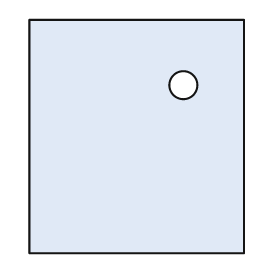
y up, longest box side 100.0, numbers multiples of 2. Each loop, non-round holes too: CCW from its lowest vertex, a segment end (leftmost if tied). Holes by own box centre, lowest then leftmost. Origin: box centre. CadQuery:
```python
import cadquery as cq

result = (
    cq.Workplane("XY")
    .moveTo(-46.0, -50.0)
    .lineTo(46.0, -50.0)
    .lineTo(46.0, 50.0)
    .lineTo(-46.0, 50.0)
    .close()
    .moveTo(20.0, 22.0)
    .circle(6.0)
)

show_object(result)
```